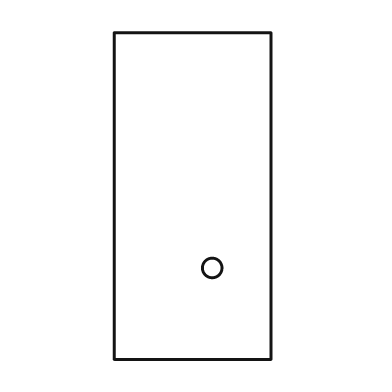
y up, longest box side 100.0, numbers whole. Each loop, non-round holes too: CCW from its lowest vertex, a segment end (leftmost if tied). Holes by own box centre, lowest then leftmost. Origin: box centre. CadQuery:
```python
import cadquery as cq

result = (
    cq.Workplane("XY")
    .moveTo(-24.0, -50.0)
    .lineTo(24.0, -50.0)
    .lineTo(24.0, 50.0)
    .lineTo(-24.0, 50.0)
    .close()
    .moveTo(6.0, -22.0)
    .circle(3.0)
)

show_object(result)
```